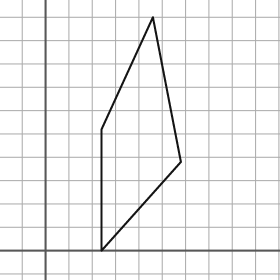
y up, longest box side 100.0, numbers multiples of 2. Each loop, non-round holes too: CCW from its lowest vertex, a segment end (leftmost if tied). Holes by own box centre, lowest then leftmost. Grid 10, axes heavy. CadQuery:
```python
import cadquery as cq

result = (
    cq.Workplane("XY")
    .moveTo(24.0, 0.0)
    .lineTo(58.0, 38.0)
    .lineTo(46.0, 100.0)
    .lineTo(24.0, 52.0)
    .close()
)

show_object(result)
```